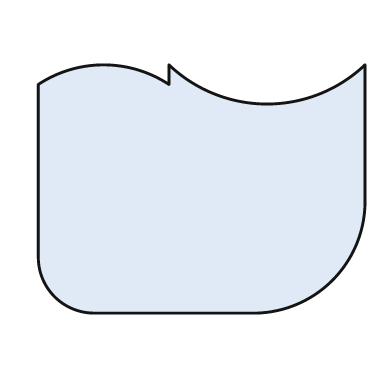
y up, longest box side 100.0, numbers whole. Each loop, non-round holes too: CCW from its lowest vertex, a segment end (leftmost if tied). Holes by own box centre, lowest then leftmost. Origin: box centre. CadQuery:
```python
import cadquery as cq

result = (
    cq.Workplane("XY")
    .moveTo(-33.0, -38.0)
    .lineTo(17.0, -38.0)
    .threePointArc((40.0, -28.0), (50.0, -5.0))
    .lineTo(50.0, 38.0)
    .threePointArc((20.0, 26.0), (-10.0, 38.0))
    .lineTo(-10.0, 32.0)
    .threePointArc((-30.0, 38.0), (-50.0, 32.0))
    .lineTo(-50.0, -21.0)
    .threePointArc((-45.0, -33.0), (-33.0, -38.0))
    .close()
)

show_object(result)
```